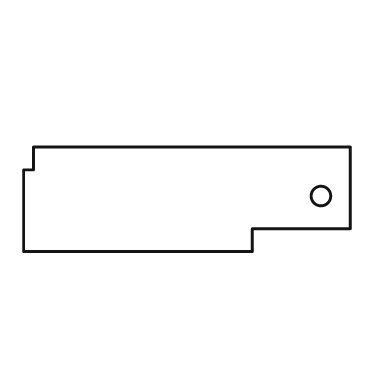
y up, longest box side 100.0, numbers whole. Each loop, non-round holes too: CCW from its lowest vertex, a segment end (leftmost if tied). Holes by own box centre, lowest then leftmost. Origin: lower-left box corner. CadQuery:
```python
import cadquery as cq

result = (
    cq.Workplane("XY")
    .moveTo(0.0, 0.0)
    .lineTo(70.0, 0.0)
    .lineTo(70.0, 7.0)
    .lineTo(100.0, 7.0)
    .lineTo(100.0, 32.0)
    .lineTo(3.0, 32.0)
    .lineTo(3.0, 25.0)
    .lineTo(0.0, 25.0)
    .close()
    .moveTo(91.0, 17.0)
    .circle(3.0)
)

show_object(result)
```